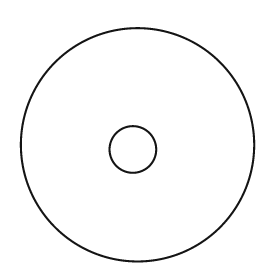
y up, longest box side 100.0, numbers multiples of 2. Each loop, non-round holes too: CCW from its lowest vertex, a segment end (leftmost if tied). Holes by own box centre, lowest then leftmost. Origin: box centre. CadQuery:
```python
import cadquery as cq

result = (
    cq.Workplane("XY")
    .moveTo(0.0, 0.0)
    .circle(50.0)
    .moveTo(-2.0, -2.0)
    .circle(10.0)
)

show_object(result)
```